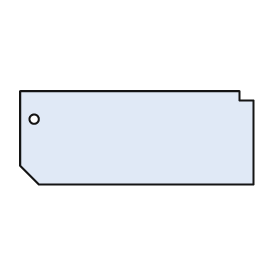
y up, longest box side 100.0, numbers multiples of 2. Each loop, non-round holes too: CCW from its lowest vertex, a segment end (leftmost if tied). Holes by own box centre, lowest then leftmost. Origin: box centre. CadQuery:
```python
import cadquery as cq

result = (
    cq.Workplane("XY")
    .moveTo(-42.0, -20.0)
    .lineTo(50.0, -20.0)
    .lineTo(50.0, 16.0)
    .lineTo(44.0, 16.0)
    .lineTo(44.0, 20.0)
    .lineTo(-50.0, 20.0)
    .lineTo(-50.0, -12.0)
    .close()
    .moveTo(-44.0, 8.0)
    .circle(2.0)
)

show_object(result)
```